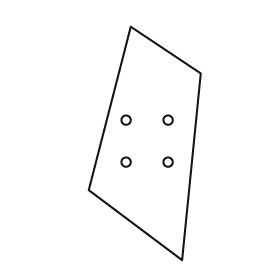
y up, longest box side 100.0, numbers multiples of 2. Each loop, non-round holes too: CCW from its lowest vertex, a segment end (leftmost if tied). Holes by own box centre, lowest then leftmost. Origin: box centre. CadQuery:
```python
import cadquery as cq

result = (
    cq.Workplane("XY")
    .moveTo(16.0, -50.0)
    .lineTo(24.0, 30.0)
    .lineTo(-6.0, 50.0)
    .lineTo(-24.0, -20.0)
    .close()
    .moveTo(-8.0, -8.0)
    .circle(2.0)
    .moveTo(10.0, -8.0)
    .circle(2.0)
    .moveTo(-8.0, 10.0)
    .circle(2.0)
    .moveTo(10.0, 10.0)
    .circle(2.0)
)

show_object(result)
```